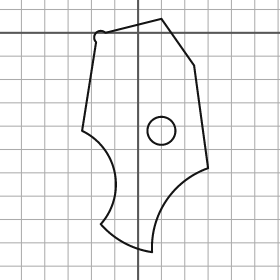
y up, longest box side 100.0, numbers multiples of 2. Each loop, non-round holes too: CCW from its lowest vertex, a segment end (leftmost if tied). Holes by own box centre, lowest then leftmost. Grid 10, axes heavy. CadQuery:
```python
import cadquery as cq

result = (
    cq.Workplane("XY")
    .moveTo(6.0, -94.0)
    .threePointArc((12.0, -72.0), (30.0, -58.0))
    .lineTo(24.0, -14.0)
    .lineTo(10.0, 6.0)
    .lineTo(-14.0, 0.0)
    .threePointArc((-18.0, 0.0), (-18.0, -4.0))
    .lineTo(-24.0, -42.0)
    .threePointArc((-10.0, -60.0), (-16.0, -82.0))
    .threePointArc((-6.0, -90.0), (6.0, -94.0))
    .close()
    .moveTo(10.0, -42.0)
    .circle(6.0)
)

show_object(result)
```